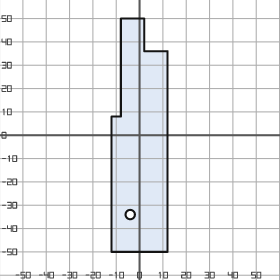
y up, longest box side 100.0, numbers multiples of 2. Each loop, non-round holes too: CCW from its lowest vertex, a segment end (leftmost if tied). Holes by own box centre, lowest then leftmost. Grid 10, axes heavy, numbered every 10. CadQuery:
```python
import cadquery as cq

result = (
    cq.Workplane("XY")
    .moveTo(-12.0, -50.0)
    .lineTo(12.0, -50.0)
    .lineTo(12.0, 36.0)
    .lineTo(2.0, 36.0)
    .lineTo(2.0, 50.0)
    .lineTo(-8.0, 50.0)
    .lineTo(-8.0, 8.0)
    .lineTo(-12.0, 8.0)
    .close()
    .moveTo(-4.0, -34.0)
    .circle(2.0)
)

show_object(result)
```